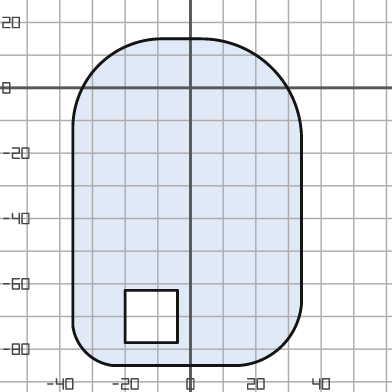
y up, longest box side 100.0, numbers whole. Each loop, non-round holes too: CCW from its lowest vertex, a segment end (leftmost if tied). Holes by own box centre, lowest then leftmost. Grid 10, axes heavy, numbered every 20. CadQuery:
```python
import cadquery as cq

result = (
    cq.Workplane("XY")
    .moveTo(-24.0, -85.0)
    .lineTo(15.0, -85.0)
    .threePointArc((28.0, -79.0), (34.0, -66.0))
    .lineTo(34.0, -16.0)
    .threePointArc((25.0, 6.0), (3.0, 15.0))
    .lineTo(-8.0, 15.0)
    .threePointArc((-28.0, 7.0), (-36.0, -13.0))
    .lineTo(-36.0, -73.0)
    .threePointArc((-32.0, -81.0), (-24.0, -85.0))
    .close()
    .moveTo(-20.0, -78.0)
    .lineTo(-4.0, -78.0)
    .lineTo(-4.0, -62.0)
    .lineTo(-20.0, -62.0)
    .close()
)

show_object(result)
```